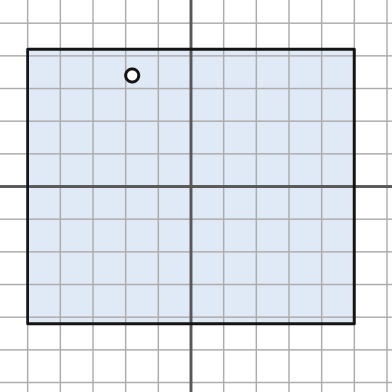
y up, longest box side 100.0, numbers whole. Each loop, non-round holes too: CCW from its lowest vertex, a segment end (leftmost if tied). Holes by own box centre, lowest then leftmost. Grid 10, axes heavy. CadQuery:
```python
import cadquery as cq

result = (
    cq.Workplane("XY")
    .moveTo(-50.0, -42.0)
    .lineTo(50.0, -42.0)
    .lineTo(50.0, 42.0)
    .lineTo(-50.0, 42.0)
    .close()
    .moveTo(-18.0, 34.0)
    .circle(2.0)
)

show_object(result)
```